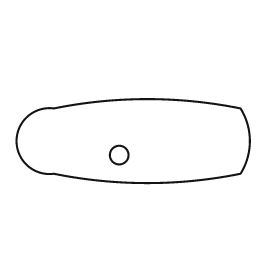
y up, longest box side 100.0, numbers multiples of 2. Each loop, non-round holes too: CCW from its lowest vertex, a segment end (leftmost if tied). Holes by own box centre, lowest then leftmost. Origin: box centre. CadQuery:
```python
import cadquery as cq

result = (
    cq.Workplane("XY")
    .moveTo(-34.0, -14.0)
    .threePointArc((6.0, -18.0), (46.0, -14.0))
    .threePointArc((50.0, 0.0), (46.0, 14.0))
    .threePointArc((6.0, 18.0), (-34.0, 14.0))
    .threePointArc((-50.0, 0.0), (-34.0, -14.0))
    .close()
    .moveTo(-6.0, -6.0)
    .circle(4.0)
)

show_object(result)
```